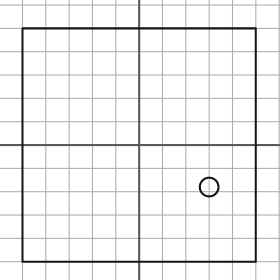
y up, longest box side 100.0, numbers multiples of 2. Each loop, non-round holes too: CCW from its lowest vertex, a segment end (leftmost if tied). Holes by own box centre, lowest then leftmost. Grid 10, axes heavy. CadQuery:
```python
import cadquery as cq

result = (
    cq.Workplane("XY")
    .moveTo(-50.0, -50.0)
    .lineTo(50.0, -50.0)
    .lineTo(50.0, 50.0)
    .lineTo(-50.0, 50.0)
    .close()
    .moveTo(30.0, -18.0)
    .circle(4.0)
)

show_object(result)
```